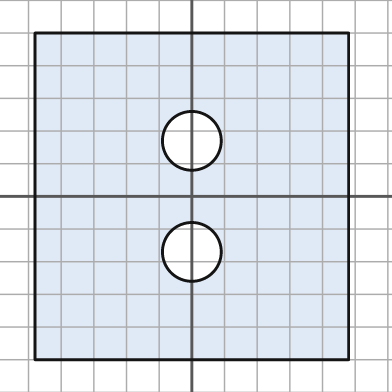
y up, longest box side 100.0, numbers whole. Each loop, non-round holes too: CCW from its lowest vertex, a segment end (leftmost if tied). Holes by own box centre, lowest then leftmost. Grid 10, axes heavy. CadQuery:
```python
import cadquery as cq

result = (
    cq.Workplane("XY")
    .moveTo(-48.0, -50.0)
    .lineTo(48.0, -50.0)
    .lineTo(48.0, 50.0)
    .lineTo(-48.0, 50.0)
    .close()
    .moveTo(0.0, -17.0)
    .circle(9.0)
    .moveTo(0.0, 17.0)
    .circle(9.0)
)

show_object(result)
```